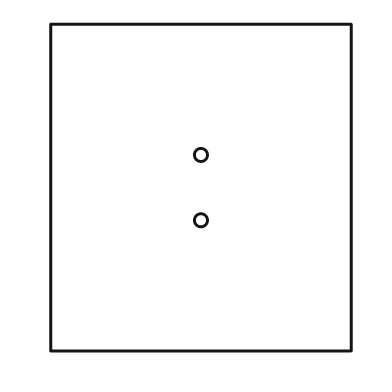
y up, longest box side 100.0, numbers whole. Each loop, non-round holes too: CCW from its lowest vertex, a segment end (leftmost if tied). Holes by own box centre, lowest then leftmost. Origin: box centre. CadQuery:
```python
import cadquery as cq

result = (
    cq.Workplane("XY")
    .moveTo(-46.0, -50.0)
    .lineTo(46.0, -50.0)
    .lineTo(46.0, 50.0)
    .lineTo(-46.0, 50.0)
    .close()
    .moveTo(0.0, -10.0)
    .circle(2.0)
    .moveTo(0.0, 10.0)
    .circle(2.0)
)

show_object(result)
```